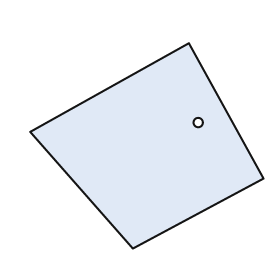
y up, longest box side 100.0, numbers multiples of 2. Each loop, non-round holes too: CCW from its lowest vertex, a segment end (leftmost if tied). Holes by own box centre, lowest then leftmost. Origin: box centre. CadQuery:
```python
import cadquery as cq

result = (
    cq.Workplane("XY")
    .moveTo(-6.0, -44.0)
    .lineTo(50.0, -14.0)
    .lineTo(18.0, 44.0)
    .lineTo(-50.0, 6.0)
    .close()
    .moveTo(22.0, 10.0)
    .circle(2.0)
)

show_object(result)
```